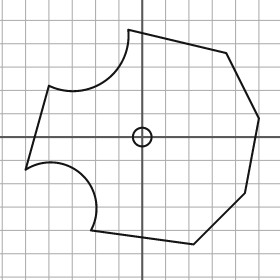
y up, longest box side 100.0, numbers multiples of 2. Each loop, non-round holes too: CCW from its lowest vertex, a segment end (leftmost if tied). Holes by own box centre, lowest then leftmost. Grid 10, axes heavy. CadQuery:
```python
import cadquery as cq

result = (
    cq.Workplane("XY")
    .moveTo(22.0, -46.0)
    .lineTo(44.0, -24.0)
    .lineTo(50.0, 8.0)
    .lineTo(36.0, 36.0)
    .lineTo(-6.0, 46.0)
    .threePointArc((-16.0, 24.0), (-40.0, 22.0))
    .lineTo(-50.0, -14.0)
    .threePointArc((-26.0, -16.0), (-22.0, -40.0))
    .close()
    .moveTo(0.0, 0.0)
    .circle(4.0)
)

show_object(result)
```